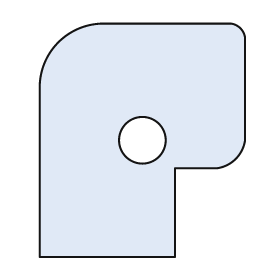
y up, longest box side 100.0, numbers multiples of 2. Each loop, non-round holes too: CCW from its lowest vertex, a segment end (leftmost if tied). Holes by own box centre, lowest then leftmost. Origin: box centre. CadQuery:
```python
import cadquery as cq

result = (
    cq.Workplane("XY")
    .moveTo(-44.0, -50.0)
    .lineTo(14.0, -50.0)
    .lineTo(14.0, -12.0)
    .lineTo(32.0, -12.0)
    .threePointArc((40.0, -8.0), (44.0, 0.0))
    .lineTo(44.0, 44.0)
    .threePointArc((42.0, 48.0), (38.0, 50.0))
    .lineTo(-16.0, 50.0)
    .threePointArc((-36.0, 42.0), (-44.0, 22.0))
    .close()
    .moveTo(0.0, 0.0)
    .circle(10.0)
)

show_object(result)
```